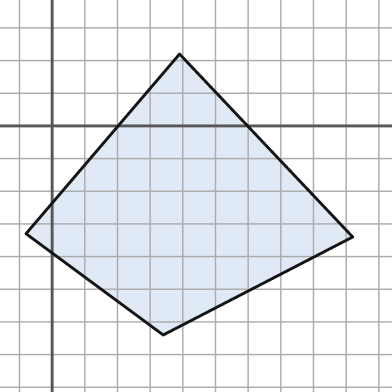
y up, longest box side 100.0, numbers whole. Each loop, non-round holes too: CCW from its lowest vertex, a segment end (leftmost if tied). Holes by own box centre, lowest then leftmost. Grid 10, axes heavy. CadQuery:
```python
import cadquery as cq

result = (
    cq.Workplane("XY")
    .moveTo(34.0, -64.0)
    .lineTo(92.0, -34.0)
    .lineTo(39.0, 22.0)
    .lineTo(-8.0, -33.0)
    .close()
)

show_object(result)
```